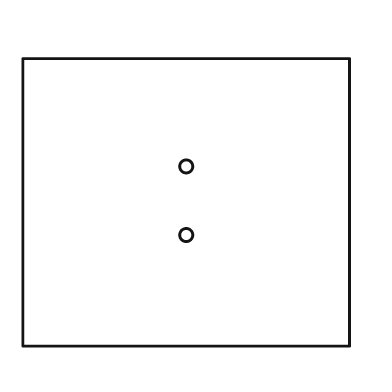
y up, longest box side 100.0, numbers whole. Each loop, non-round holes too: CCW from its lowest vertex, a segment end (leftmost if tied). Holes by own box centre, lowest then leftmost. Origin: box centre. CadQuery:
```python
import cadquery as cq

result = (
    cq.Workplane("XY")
    .moveTo(-50.0, -44.0)
    .lineTo(50.0, -44.0)
    .lineTo(50.0, 44.0)
    .lineTo(-50.0, 44.0)
    .close()
    .moveTo(0.0, -10.0)
    .circle(2.0)
    .moveTo(0.0, 11.0)
    .circle(2.0)
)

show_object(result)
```